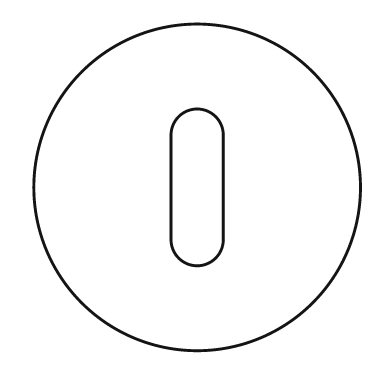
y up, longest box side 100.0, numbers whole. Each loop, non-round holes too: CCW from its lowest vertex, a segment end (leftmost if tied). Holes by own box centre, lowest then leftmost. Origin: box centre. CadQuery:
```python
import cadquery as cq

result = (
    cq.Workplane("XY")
    .moveTo(0.0, 0.0)
    .circle(50.0)
    .moveTo(-8.0, -16.0)
    .threePointArc((0.0, -24.0), (8.0, -16.0))
    .lineTo(8.0, 16.0)
    .threePointArc((0.0, 24.0), (-8.0, 16.0))
    .close()
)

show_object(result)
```